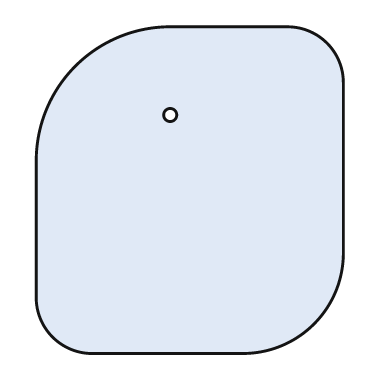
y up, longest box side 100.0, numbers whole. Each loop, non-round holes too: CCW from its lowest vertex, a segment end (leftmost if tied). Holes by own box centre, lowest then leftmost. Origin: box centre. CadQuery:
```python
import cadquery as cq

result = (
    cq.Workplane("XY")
    .moveTo(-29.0, -50.0)
    .lineTo(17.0, -50.0)
    .threePointArc((38.0, -41.0), (47.0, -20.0))
    .lineTo(47.0, 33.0)
    .threePointArc((42.0, 45.0), (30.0, 50.0))
    .lineTo(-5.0, 50.0)
    .threePointArc((-35.0, 38.0), (-47.0, 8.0))
    .lineTo(-47.0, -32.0)
    .threePointArc((-42.0, -45.0), (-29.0, -50.0))
    .close()
    .moveTo(-6.0, 23.0)
    .circle(2.0)
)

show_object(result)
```